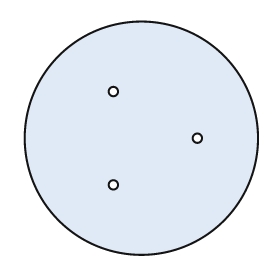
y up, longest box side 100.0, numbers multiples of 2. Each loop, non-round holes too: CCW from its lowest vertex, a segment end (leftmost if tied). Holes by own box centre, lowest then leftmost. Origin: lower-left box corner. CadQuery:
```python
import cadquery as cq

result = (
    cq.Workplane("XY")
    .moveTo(50.0, 50.0)
    .circle(50.0)
    .moveTo(38.0, 30.0)
    .circle(2.0)
    .moveTo(74.0, 50.0)
    .circle(2.0)
    .moveTo(38.0, 70.0)
    .circle(2.0)
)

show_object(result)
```